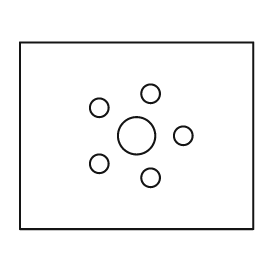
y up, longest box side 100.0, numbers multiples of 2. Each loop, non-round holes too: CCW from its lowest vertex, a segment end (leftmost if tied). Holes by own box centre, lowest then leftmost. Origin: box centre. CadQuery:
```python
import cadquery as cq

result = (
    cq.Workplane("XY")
    .moveTo(-50.0, -40.0)
    .lineTo(50.0, -40.0)
    .lineTo(50.0, 40.0)
    .lineTo(-50.0, 40.0)
    .close()
    .moveTo(6.0, -18.0)
    .circle(4.0)
    .moveTo(-16.0, -12.0)
    .circle(4.0)
    .moveTo(0.0, 0.0)
    .circle(8.0)
    .moveTo(20.0, 0.0)
    .circle(4.0)
    .moveTo(-16.0, 12.0)
    .circle(4.0)
    .moveTo(6.0, 18.0)
    .circle(4.0)
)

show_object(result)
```